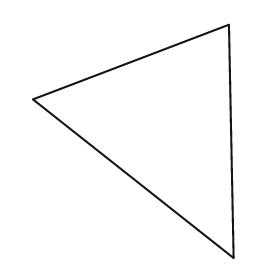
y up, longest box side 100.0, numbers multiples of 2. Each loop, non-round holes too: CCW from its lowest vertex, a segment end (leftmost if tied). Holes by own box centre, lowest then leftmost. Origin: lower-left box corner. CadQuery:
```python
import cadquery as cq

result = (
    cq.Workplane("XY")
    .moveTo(86.0, 0.0)
    .lineTo(84.0, 100.0)
    .lineTo(0.0, 68.0)
    .close()
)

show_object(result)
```